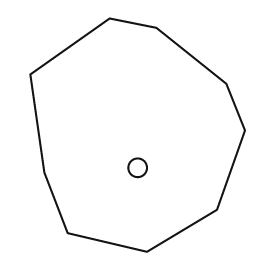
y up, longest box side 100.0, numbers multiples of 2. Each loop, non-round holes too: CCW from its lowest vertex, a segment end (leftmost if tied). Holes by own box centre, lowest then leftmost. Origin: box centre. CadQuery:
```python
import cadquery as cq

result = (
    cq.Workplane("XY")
    .moveTo(4.0, -50.0)
    .lineTo(34.0, -32.0)
    .lineTo(46.0, 2.0)
    .lineTo(38.0, 22.0)
    .lineTo(8.0, 46.0)
    .lineTo(-12.0, 50.0)
    .lineTo(-46.0, 26.0)
    .lineTo(-40.0, -16.0)
    .lineTo(-30.0, -42.0)
    .close()
    .moveTo(0.0, -14.0)
    .circle(4.0)
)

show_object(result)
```